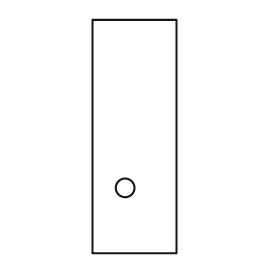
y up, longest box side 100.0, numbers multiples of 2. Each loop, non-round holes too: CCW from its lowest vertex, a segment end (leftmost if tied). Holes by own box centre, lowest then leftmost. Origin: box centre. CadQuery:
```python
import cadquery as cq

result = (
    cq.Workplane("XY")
    .moveTo(-18.0, -50.0)
    .lineTo(18.0, -50.0)
    .lineTo(18.0, 50.0)
    .lineTo(-18.0, 50.0)
    .close()
    .moveTo(-4.0, -22.0)
    .circle(4.0)
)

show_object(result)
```